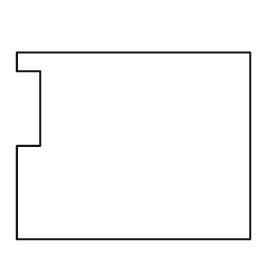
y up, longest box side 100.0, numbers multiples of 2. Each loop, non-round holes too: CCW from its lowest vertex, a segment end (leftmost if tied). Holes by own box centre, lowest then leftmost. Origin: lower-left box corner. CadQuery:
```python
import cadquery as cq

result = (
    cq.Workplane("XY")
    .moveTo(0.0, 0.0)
    .lineTo(100.0, 0.0)
    .lineTo(100.0, 80.0)
    .lineTo(0.0, 80.0)
    .lineTo(0.0, 72.0)
    .lineTo(10.0, 72.0)
    .lineTo(10.0, 40.0)
    .lineTo(0.0, 40.0)
    .close()
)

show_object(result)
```